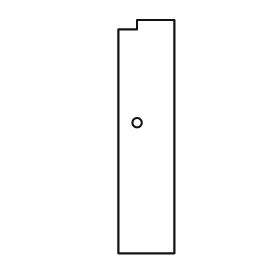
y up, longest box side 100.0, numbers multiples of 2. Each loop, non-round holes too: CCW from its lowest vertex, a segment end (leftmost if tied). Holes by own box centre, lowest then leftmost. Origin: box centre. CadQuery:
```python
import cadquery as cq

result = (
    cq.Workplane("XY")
    .moveTo(-12.0, -50.0)
    .lineTo(12.0, -50.0)
    .lineTo(12.0, 50.0)
    .lineTo(-4.0, 50.0)
    .lineTo(-4.0, 46.0)
    .lineTo(-12.0, 46.0)
    .close()
    .moveTo(-4.0, 6.0)
    .circle(2.0)
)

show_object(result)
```